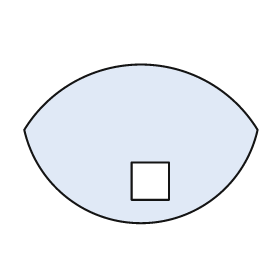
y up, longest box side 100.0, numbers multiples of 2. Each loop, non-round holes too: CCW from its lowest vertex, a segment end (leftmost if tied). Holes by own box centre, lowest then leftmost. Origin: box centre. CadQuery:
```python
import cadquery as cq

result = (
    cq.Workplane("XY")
    .moveTo(-50.0, 6.0)
    .threePointArc((0.0, -34.0), (50.0, 6.0))
    .threePointArc((0.0, 34.0), (-50.0, 6.0))
    .close()
    .moveTo(-4.0, -24.0)
    .lineTo(12.0, -24.0)
    .lineTo(12.0, -8.0)
    .lineTo(-4.0, -8.0)
    .close()
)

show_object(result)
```